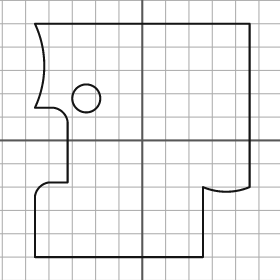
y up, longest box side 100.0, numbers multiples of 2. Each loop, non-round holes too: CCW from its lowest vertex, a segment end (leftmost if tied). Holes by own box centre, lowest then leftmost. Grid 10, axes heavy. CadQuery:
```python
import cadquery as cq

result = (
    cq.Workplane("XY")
    .moveTo(-46.0, -50.0)
    .lineTo(26.0, -50.0)
    .lineTo(26.0, -20.0)
    .threePointArc((36.0, -22.0), (46.0, -20.0))
    .lineTo(46.0, 50.0)
    .lineTo(-46.0, 50.0)
    .threePointArc((-42.0, 32.0), (-46.0, 14.0))
    .lineTo(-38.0, 14.0)
    .threePointArc((-34.0, 12.0), (-32.0, 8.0))
    .lineTo(-32.0, -18.0)
    .lineTo(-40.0, -18.0)
    .threePointArc((-44.0, -20.0), (-46.0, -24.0))
    .close()
    .moveTo(-24.0, 18.0)
    .circle(6.0)
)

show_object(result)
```